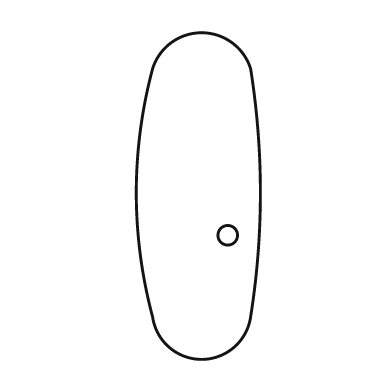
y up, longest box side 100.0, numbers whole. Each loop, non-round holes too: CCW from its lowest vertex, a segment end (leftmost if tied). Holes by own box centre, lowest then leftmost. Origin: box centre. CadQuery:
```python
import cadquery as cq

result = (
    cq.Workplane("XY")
    .moveTo(-14.0, -37.0)
    .threePointArc((1.0, -50.0), (16.0, -37.0))
    .threePointArc((19.0, 1.0), (16.0, 39.0))
    .threePointArc((1.0, 50.0), (-14.0, 39.0))
    .threePointArc((-19.0, 1.0), (-14.0, -37.0))
    .close()
    .moveTo(9.0, -12.0)
    .circle(3.0)
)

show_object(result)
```